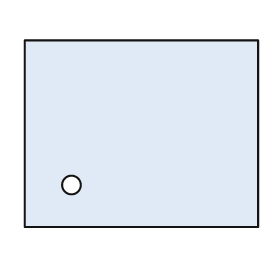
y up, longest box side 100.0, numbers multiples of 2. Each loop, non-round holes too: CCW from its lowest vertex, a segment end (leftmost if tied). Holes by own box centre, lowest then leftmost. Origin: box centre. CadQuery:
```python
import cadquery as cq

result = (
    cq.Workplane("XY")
    .moveTo(-50.0, -40.0)
    .lineTo(50.0, -40.0)
    .lineTo(50.0, 40.0)
    .lineTo(-50.0, 40.0)
    .close()
    .moveTo(-30.0, -22.0)
    .circle(4.0)
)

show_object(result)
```